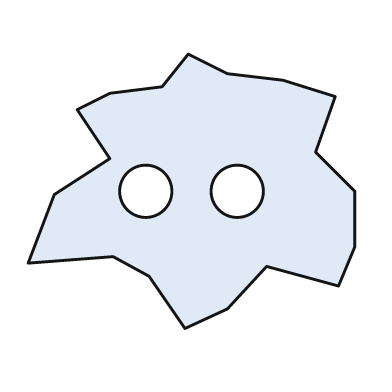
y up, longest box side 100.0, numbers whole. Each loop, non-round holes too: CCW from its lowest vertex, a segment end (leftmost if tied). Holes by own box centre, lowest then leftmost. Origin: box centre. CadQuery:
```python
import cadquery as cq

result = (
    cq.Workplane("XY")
    .moveTo(-2.0, -42.0)
    .lineTo(11.0, -36.0)
    .lineTo(23.0, -23.0)
    .lineTo(45.0, -29.0)
    .lineTo(50.0, -17.0)
    .lineTo(50.0, 0.0)
    .lineTo(38.0, 12.0)
    .lineTo(44.0, 29.0)
    .lineTo(28.0, 34.0)
    .lineTo(11.0, 36.0)
    .lineTo(-1.0, 42.0)
    .lineTo(-9.0, 32.0)
    .lineTo(-25.0, 30.0)
    .lineTo(-35.0, 25.0)
    .lineTo(-25.0, 10.0)
    .lineTo(-42.0, -1.0)
    .lineTo(-50.0, -22.0)
    .lineTo(-24.0, -20.0)
    .lineTo(-13.0, -26.0)
    .close()
    .moveTo(-14.0, 0.0)
    .circle(8.0)
    .moveTo(14.0, 0.0)
    .circle(8.0)
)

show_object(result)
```